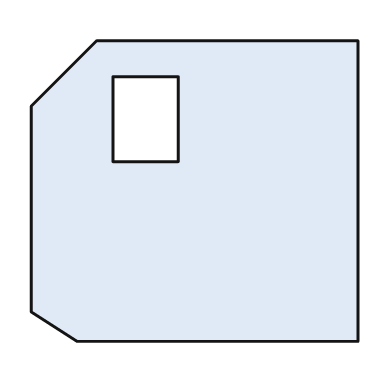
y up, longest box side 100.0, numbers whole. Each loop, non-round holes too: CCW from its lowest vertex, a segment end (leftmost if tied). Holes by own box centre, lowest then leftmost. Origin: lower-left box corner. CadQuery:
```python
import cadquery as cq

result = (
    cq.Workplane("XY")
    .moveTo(14.0, 0.0)
    .lineTo(100.0, 0.0)
    .lineTo(100.0, 92.0)
    .lineTo(20.0, 92.0)
    .lineTo(0.0, 72.0)
    .lineTo(0.0, 9.0)
    .close()
    .moveTo(25.0, 55.0)
    .lineTo(45.0, 55.0)
    .lineTo(45.0, 81.0)
    .lineTo(25.0, 81.0)
    .close()
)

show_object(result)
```